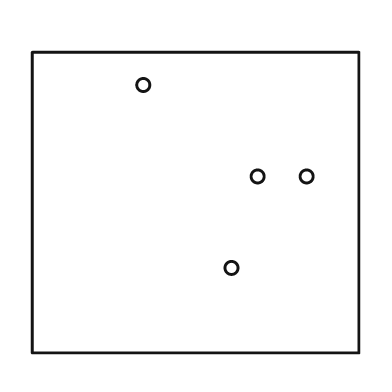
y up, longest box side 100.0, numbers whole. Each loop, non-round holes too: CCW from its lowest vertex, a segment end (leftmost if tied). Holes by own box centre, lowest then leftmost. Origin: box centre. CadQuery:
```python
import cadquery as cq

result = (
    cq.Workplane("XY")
    .moveTo(-50.0, -46.0)
    .lineTo(50.0, -46.0)
    .lineTo(50.0, 46.0)
    .lineTo(-50.0, 46.0)
    .close()
    .moveTo(11.0, -20.0)
    .circle(2.0)
    .moveTo(19.0, 8.0)
    .circle(2.0)
    .moveTo(34.0, 8.0)
    .circle(2.0)
    .moveTo(-16.0, 36.0)
    .circle(2.0)
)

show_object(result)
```